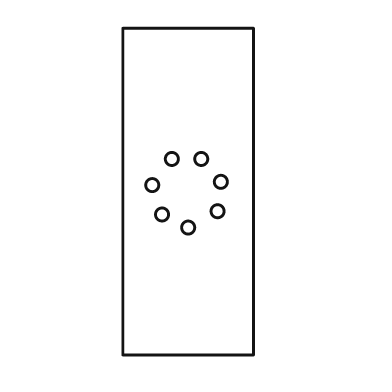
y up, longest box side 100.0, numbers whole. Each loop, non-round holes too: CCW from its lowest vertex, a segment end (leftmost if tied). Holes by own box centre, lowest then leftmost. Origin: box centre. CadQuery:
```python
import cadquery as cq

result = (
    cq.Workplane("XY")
    .moveTo(-20.0, -50.0)
    .lineTo(20.0, -50.0)
    .lineTo(20.0, 50.0)
    .lineTo(-20.0, 50.0)
    .close()
    .moveTo(0.0, -11.0)
    .circle(2.0)
    .moveTo(-8.0, -7.0)
    .circle(2.0)
    .moveTo(9.0, -6.0)
    .circle(2.0)
    .moveTo(-11.0, 2.0)
    .circle(2.0)
    .moveTo(10.0, 3.0)
    .circle(2.0)
    .moveTo(-5.0, 10.0)
    .circle(2.0)
    .moveTo(4.0, 10.0)
    .circle(2.0)
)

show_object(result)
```